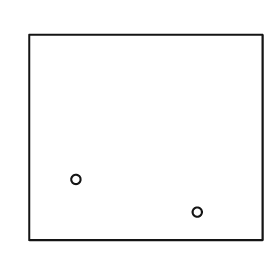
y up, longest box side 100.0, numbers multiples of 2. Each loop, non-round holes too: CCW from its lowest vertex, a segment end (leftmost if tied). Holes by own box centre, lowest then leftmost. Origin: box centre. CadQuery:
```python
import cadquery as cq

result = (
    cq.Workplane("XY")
    .moveTo(-50.0, -44.0)
    .lineTo(50.0, -44.0)
    .lineTo(50.0, 44.0)
    .lineTo(-50.0, 44.0)
    .close()
    .moveTo(22.0, -32.0)
    .circle(2.0)
    .moveTo(-30.0, -18.0)
    .circle(2.0)
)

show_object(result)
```